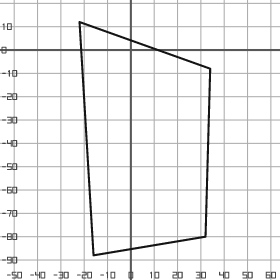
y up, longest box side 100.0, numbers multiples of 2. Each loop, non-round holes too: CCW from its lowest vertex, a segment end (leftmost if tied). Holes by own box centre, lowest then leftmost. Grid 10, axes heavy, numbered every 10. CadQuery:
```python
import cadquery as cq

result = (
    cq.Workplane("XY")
    .moveTo(-16.0, -88.0)
    .lineTo(32.0, -80.0)
    .lineTo(34.0, -8.0)
    .lineTo(-22.0, 12.0)
    .close()
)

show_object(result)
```